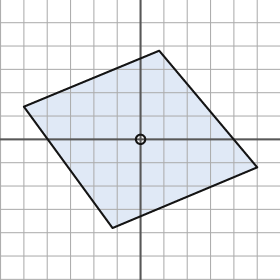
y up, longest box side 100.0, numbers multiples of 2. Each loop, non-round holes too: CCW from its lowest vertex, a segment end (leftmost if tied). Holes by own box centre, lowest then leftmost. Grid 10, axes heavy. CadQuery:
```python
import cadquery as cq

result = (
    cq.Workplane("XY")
    .moveTo(-12.0, -38.0)
    .lineTo(50.0, -12.0)
    .lineTo(8.0, 38.0)
    .lineTo(-50.0, 14.0)
    .close()
    .moveTo(0.0, 0.0)
    .circle(2.0)
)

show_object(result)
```